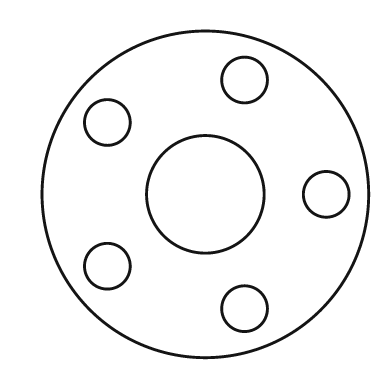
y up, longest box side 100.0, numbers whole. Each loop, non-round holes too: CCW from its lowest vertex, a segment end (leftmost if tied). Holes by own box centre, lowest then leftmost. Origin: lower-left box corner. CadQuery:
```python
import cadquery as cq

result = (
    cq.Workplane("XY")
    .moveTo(50.0, 50.0)
    .circle(50.0)
    .moveTo(62.0, 15.0)
    .circle(7.0)
    .moveTo(20.0, 28.0)
    .circle(7.0)
    .moveTo(50.0, 50.0)
    .circle(18.0)
    .moveTo(87.0, 50.0)
    .circle(7.0)
    .moveTo(20.0, 72.0)
    .circle(7.0)
    .moveTo(62.0, 85.0)
    .circle(7.0)
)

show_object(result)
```